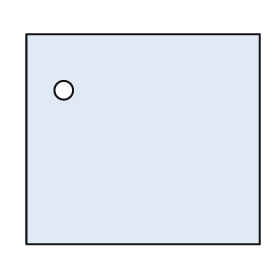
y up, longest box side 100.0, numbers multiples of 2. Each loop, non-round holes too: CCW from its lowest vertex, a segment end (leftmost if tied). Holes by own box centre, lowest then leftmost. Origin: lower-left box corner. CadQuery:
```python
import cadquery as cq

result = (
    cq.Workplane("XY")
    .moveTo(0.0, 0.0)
    .lineTo(100.0, 0.0)
    .lineTo(100.0, 90.0)
    .lineTo(0.0, 90.0)
    .close()
    .moveTo(16.0, 66.0)
    .circle(4.0)
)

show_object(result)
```